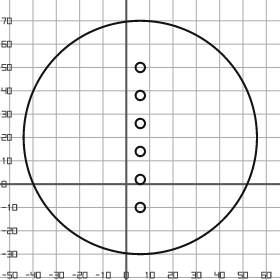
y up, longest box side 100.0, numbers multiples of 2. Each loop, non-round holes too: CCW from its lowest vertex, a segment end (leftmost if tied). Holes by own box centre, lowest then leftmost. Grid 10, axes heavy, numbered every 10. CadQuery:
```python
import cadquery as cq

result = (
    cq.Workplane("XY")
    .moveTo(6.0, 20.0)
    .circle(50.0)
    .moveTo(6.0, -10.0)
    .circle(2.0)
    .moveTo(6.0, 2.0)
    .circle(2.0)
    .moveTo(6.0, 14.0)
    .circle(2.0)
    .moveTo(6.0, 26.0)
    .circle(2.0)
    .moveTo(6.0, 38.0)
    .circle(2.0)
    .moveTo(6.0, 50.0)
    .circle(2.0)
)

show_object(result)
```